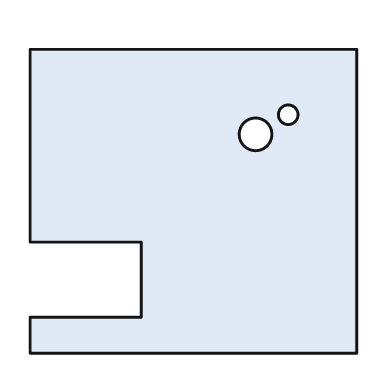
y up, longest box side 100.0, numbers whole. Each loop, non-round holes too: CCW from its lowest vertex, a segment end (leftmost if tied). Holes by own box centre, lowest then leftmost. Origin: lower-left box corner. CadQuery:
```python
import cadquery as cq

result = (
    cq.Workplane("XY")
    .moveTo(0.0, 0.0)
    .lineTo(100.0, 0.0)
    .lineTo(100.0, 93.0)
    .lineTo(0.0, 93.0)
    .lineTo(0.0, 34.0)
    .lineTo(34.0, 34.0)
    .lineTo(34.0, 11.0)
    .lineTo(0.0, 11.0)
    .close()
    .moveTo(69.0, 67.0)
    .circle(5.0)
    .moveTo(79.0, 73.0)
    .circle(3.0)
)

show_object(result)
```